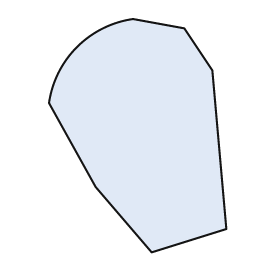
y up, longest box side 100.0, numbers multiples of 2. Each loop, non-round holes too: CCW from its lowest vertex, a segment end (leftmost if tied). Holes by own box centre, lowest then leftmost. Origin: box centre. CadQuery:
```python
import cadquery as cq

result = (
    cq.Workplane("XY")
    .moveTo(6.0, -50.0)
    .lineTo(38.0, -40.0)
    .lineTo(32.0, 28.0)
    .lineTo(20.0, 46.0)
    .lineTo(-2.0, 50.0)
    .threePointArc((-26.0, 38.0), (-38.0, 14.0))
    .lineTo(-18.0, -22.0)
    .close()
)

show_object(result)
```